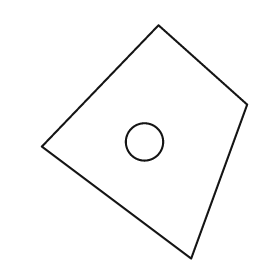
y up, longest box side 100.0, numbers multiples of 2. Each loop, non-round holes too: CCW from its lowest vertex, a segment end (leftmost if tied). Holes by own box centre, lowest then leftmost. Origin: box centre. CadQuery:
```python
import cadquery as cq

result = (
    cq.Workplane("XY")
    .moveTo(20.0, -50.0)
    .lineTo(44.0, 16.0)
    .lineTo(6.0, 50.0)
    .lineTo(-44.0, -2.0)
    .close()
    .moveTo(0.0, 0.0)
    .circle(8.0)
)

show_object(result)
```